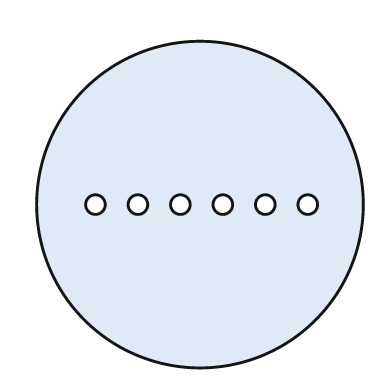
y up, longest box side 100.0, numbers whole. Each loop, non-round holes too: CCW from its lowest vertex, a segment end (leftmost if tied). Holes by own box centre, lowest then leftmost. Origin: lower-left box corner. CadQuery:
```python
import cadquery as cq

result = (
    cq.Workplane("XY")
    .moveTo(50.0, 50.0)
    .circle(50.0)
    .moveTo(18.0, 50.0)
    .circle(3.0)
    .moveTo(31.0, 50.0)
    .circle(3.0)
    .moveTo(44.0, 50.0)
    .circle(3.0)
    .moveTo(57.0, 50.0)
    .circle(3.0)
    .moveTo(70.0, 50.0)
    .circle(3.0)
    .moveTo(83.0, 50.0)
    .circle(3.0)
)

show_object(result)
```